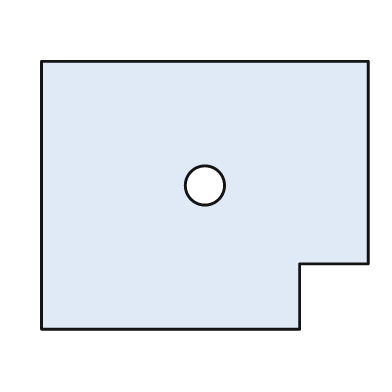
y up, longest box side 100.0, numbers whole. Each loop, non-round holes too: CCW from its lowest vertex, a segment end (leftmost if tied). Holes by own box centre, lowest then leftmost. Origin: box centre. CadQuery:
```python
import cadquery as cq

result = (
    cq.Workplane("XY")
    .moveTo(-50.0, -41.0)
    .lineTo(29.0, -41.0)
    .lineTo(29.0, -21.0)
    .lineTo(50.0, -21.0)
    .lineTo(50.0, 41.0)
    .lineTo(-50.0, 41.0)
    .close()
    .moveTo(0.0, 3.0)
    .circle(6.0)
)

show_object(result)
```